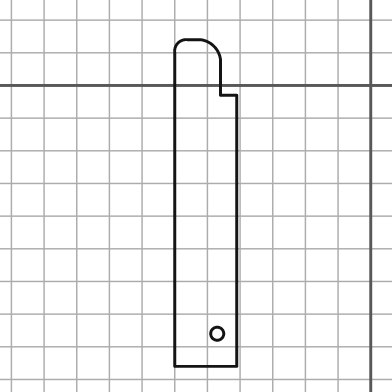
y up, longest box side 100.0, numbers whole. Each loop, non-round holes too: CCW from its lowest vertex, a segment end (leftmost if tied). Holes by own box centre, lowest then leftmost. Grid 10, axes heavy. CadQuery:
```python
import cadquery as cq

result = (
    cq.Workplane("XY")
    .moveTo(-60.0, -86.0)
    .lineTo(-41.0, -86.0)
    .lineTo(-41.0, -3.0)
    .lineTo(-46.0, -3.0)
    .lineTo(-46.0, 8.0)
    .threePointArc((-48.0, 12.0), (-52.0, 14.0))
    .lineTo(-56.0, 14.0)
    .threePointArc((-59.0, 13.0), (-60.0, 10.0))
    .close()
    .moveTo(-47.0, -76.0)
    .circle(2.0)
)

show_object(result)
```